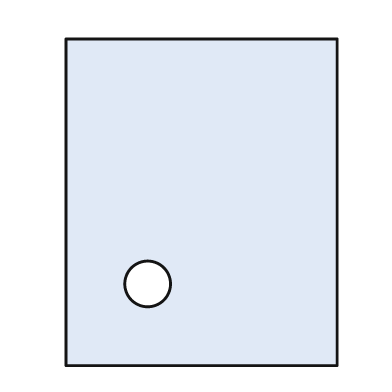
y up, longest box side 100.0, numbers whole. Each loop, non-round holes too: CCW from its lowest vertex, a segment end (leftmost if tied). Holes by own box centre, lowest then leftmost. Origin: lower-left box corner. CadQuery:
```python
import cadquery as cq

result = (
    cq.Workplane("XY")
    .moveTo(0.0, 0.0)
    .lineTo(83.0, 0.0)
    .lineTo(83.0, 100.0)
    .lineTo(0.0, 100.0)
    .close()
    .moveTo(25.0, 25.0)
    .circle(7.0)
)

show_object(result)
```